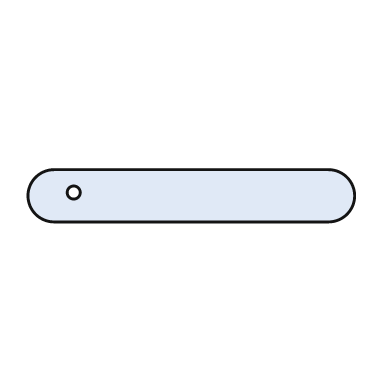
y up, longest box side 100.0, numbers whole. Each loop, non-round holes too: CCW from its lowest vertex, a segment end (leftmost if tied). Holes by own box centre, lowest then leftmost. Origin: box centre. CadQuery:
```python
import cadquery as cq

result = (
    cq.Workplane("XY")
    .moveTo(-42.0, -8.0)
    .lineTo(42.0, -8.0)
    .threePointArc((50.0, 0.0), (42.0, 8.0))
    .lineTo(-42.0, 8.0)
    .threePointArc((-50.0, 0.0), (-42.0, -8.0))
    .close()
    .moveTo(-36.0, 1.0)
    .circle(2.0)
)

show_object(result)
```